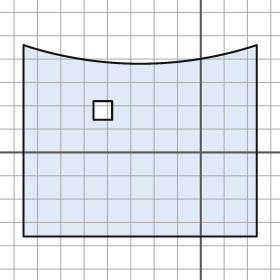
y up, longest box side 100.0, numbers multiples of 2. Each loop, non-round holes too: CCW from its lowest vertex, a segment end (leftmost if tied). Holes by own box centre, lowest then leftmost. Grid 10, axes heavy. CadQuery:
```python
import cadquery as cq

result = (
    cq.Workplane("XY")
    .moveTo(-76.0, -36.0)
    .lineTo(24.0, -36.0)
    .lineTo(24.0, 46.0)
    .threePointArc((-26.0, 38.0), (-76.0, 46.0))
    .close()
    .moveTo(-46.0, 14.0)
    .lineTo(-38.0, 14.0)
    .lineTo(-38.0, 22.0)
    .lineTo(-46.0, 22.0)
    .close()
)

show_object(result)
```